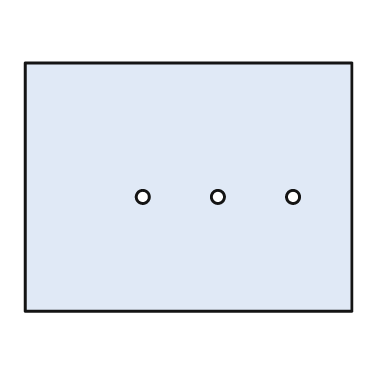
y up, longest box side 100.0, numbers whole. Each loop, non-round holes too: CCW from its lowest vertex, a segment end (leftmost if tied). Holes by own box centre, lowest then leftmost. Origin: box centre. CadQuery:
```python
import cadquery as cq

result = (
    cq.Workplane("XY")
    .moveTo(-50.0, -38.0)
    .lineTo(50.0, -38.0)
    .lineTo(50.0, 38.0)
    .lineTo(-50.0, 38.0)
    .close()
    .moveTo(-14.0, -3.0)
    .circle(2.0)
    .moveTo(9.0, -3.0)
    .circle(2.0)
    .moveTo(32.0, -3.0)
    .circle(2.0)
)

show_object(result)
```